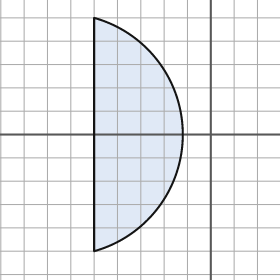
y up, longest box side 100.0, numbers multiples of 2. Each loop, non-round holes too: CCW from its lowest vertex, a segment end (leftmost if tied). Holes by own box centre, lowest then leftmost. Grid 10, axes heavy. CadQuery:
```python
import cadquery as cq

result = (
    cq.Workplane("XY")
    .moveTo(-50.0, -50.0)
    .threePointArc((-12.0, 0.0), (-50.0, 50.0))
    .close()
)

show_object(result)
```